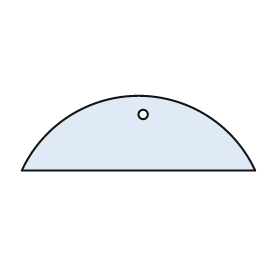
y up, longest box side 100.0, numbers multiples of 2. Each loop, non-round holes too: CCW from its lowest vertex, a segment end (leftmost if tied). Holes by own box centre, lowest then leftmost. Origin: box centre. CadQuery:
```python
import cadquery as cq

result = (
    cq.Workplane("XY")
    .moveTo(-50.0, -16.0)
    .lineTo(50.0, -16.0)
    .threePointArc((0.0, 16.0), (-50.0, -16.0))
    .close()
    .moveTo(2.0, 8.0)
    .circle(2.0)
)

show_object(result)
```